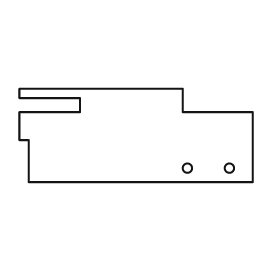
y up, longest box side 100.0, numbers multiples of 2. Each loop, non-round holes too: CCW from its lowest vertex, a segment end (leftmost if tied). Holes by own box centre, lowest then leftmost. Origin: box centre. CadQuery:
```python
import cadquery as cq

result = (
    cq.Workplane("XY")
    .moveTo(-46.0, -20.0)
    .lineTo(50.0, -20.0)
    .lineTo(50.0, 10.0)
    .lineTo(20.0, 10.0)
    .lineTo(20.0, 20.0)
    .lineTo(-50.0, 20.0)
    .lineTo(-50.0, 16.0)
    .lineTo(-24.0, 16.0)
    .lineTo(-24.0, 10.0)
    .lineTo(-50.0, 10.0)
    .lineTo(-50.0, -2.0)
    .lineTo(-46.0, -2.0)
    .close()
    .moveTo(22.0, -14.0)
    .circle(2.0)
    .moveTo(40.0, -14.0)
    .circle(2.0)
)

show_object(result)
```